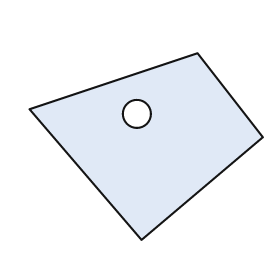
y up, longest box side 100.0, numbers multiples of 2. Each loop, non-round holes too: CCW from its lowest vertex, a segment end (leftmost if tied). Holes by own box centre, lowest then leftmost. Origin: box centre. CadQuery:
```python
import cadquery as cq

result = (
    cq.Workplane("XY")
    .moveTo(-2.0, -40.0)
    .lineTo(50.0, 4.0)
    .lineTo(22.0, 40.0)
    .lineTo(-50.0, 16.0)
    .close()
    .moveTo(-4.0, 14.0)
    .circle(6.0)
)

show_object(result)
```